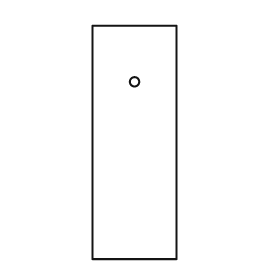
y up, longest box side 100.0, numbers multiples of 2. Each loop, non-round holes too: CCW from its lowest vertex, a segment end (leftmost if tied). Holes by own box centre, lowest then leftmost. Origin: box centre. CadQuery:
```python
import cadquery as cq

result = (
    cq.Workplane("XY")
    .moveTo(-18.0, -50.0)
    .lineTo(18.0, -50.0)
    .lineTo(18.0, 50.0)
    .lineTo(-18.0, 50.0)
    .close()
    .moveTo(0.0, 26.0)
    .circle(2.0)
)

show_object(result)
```